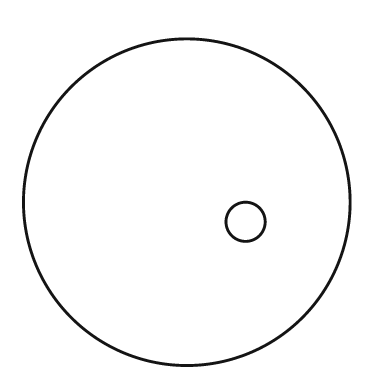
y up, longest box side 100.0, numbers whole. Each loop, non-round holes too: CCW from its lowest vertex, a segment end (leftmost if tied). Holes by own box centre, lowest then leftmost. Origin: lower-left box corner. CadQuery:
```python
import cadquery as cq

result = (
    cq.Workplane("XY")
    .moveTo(50.0, 50.0)
    .circle(50.0)
    .moveTo(68.0, 44.0)
    .circle(6.0)
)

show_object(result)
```